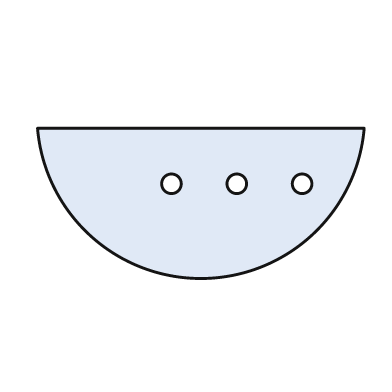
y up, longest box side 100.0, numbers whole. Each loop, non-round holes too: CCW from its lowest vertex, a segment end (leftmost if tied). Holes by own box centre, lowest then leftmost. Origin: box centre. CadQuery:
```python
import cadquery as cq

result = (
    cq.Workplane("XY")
    .moveTo(-50.0, 23.0)
    .threePointArc((0.0, -23.0), (50.0, 23.0))
    .close()
    .moveTo(-9.0, 6.0)
    .circle(3.0)
    .moveTo(11.0, 6.0)
    .circle(3.0)
    .moveTo(31.0, 6.0)
    .circle(3.0)
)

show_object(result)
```